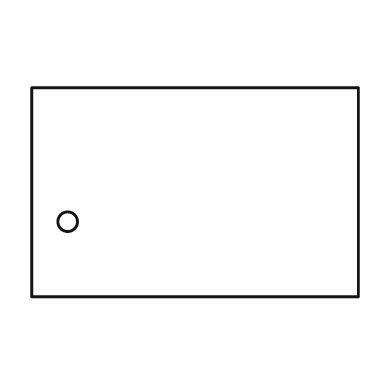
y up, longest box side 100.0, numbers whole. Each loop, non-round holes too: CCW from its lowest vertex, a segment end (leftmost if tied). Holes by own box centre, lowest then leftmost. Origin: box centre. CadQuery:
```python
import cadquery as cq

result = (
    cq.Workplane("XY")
    .moveTo(-50.0, -32.0)
    .lineTo(50.0, -32.0)
    .lineTo(50.0, 32.0)
    .lineTo(-50.0, 32.0)
    .close()
    .moveTo(-39.0, -9.0)
    .circle(3.0)
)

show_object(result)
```